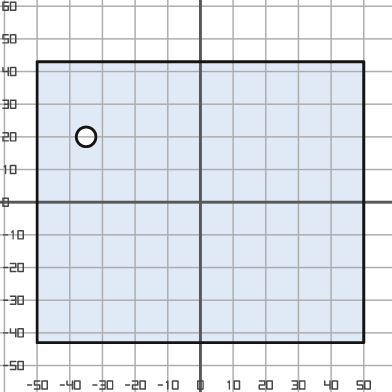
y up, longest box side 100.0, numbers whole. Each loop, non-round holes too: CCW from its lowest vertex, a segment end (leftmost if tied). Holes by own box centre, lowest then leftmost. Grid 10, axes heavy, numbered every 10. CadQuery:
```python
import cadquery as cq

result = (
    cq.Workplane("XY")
    .moveTo(-50.0, -43.0)
    .lineTo(50.0, -43.0)
    .lineTo(50.0, 43.0)
    .lineTo(-50.0, 43.0)
    .close()
    .moveTo(-35.0, 20.0)
    .circle(3.0)
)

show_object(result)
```